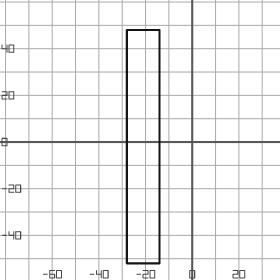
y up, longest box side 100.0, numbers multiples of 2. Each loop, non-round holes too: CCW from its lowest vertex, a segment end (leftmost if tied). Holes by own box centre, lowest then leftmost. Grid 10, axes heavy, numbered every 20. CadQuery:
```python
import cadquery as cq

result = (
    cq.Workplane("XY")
    .moveTo(-28.0, -52.0)
    .lineTo(-14.0, -52.0)
    .lineTo(-14.0, 48.0)
    .lineTo(-28.0, 48.0)
    .close()
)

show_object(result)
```